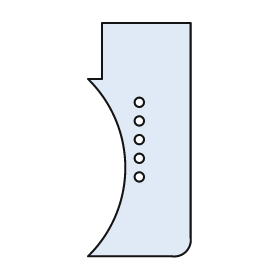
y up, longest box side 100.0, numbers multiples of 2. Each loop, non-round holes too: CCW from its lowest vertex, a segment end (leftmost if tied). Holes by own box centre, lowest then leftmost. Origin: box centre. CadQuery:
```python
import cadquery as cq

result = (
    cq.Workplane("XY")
    .moveTo(-22.0, -50.0)
    .lineTo(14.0, -50.0)
    .threePointArc((20.0, -48.0), (22.0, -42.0))
    .lineTo(22.0, 50.0)
    .lineTo(-16.0, 50.0)
    .lineTo(-16.0, 26.0)
    .lineTo(-22.0, 26.0)
    .threePointArc((-6.0, -12.0), (-22.0, -50.0))
    .close()
    .moveTo(0.0, -16.0)
    .circle(2.0)
    .moveTo(0.0, -8.0)
    .circle(2.0)
    .moveTo(0.0, 0.0)
    .circle(2.0)
    .moveTo(0.0, 8.0)
    .circle(2.0)
    .moveTo(0.0, 16.0)
    .circle(2.0)
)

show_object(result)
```